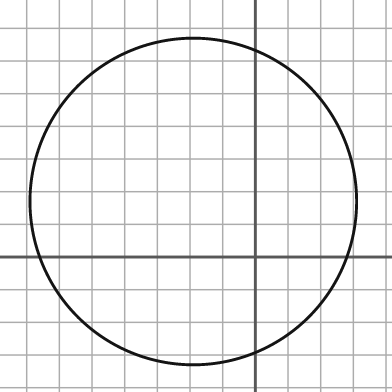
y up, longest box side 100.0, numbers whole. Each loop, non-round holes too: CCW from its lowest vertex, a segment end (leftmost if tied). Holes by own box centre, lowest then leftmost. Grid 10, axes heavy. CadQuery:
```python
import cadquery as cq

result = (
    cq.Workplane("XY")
    .moveTo(-19.0, 17.0)
    .circle(50.0)
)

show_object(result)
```